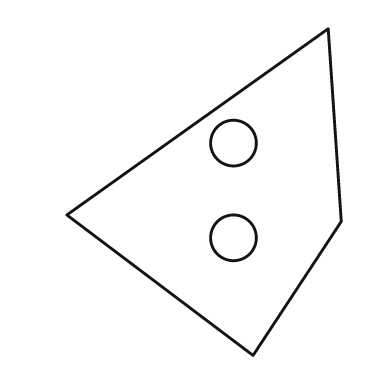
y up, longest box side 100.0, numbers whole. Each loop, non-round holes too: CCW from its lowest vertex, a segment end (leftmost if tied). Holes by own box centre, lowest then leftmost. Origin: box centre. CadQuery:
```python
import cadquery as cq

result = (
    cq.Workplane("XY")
    .moveTo(15.0, -50.0)
    .lineTo(42.0, -9.0)
    .lineTo(38.0, 50.0)
    .lineTo(-42.0, -7.0)
    .close()
    .moveTo(9.0, -14.0)
    .circle(7.0)
    .moveTo(9.0, 15.0)
    .circle(7.0)
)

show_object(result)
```